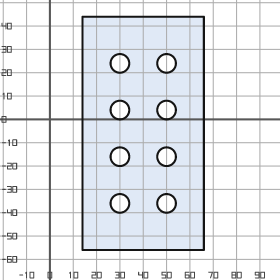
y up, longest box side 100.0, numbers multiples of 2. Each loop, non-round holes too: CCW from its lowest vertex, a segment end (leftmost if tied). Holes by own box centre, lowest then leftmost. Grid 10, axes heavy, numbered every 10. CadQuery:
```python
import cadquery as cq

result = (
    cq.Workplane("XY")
    .moveTo(14.0, -56.0)
    .lineTo(66.0, -56.0)
    .lineTo(66.0, 44.0)
    .lineTo(14.0, 44.0)
    .close()
    .moveTo(30.0, -36.0)
    .circle(4.0)
    .moveTo(50.0, -36.0)
    .circle(4.0)
    .moveTo(30.0, -16.0)
    .circle(4.0)
    .moveTo(50.0, -16.0)
    .circle(4.0)
    .moveTo(30.0, 4.0)
    .circle(4.0)
    .moveTo(50.0, 4.0)
    .circle(4.0)
    .moveTo(30.0, 24.0)
    .circle(4.0)
    .moveTo(50.0, 24.0)
    .circle(4.0)
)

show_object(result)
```